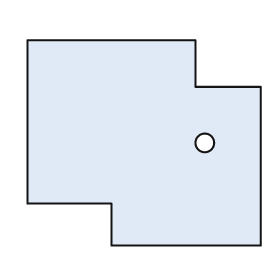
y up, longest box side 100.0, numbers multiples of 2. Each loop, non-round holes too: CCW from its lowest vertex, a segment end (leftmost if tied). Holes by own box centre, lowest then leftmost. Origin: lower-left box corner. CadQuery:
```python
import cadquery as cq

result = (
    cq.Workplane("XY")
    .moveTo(36.0, 0.0)
    .lineTo(100.0, 0.0)
    .lineTo(100.0, 68.0)
    .lineTo(72.0, 68.0)
    .lineTo(72.0, 88.0)
    .lineTo(0.0, 88.0)
    .lineTo(0.0, 18.0)
    .lineTo(36.0, 18.0)
    .close()
    .moveTo(76.0, 44.0)
    .circle(4.0)
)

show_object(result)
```